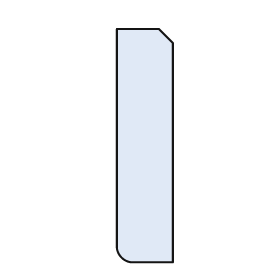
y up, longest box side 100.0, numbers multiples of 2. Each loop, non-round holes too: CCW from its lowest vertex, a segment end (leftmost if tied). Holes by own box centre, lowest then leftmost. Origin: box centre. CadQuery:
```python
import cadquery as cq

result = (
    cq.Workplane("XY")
    .moveTo(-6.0, -50.0)
    .lineTo(12.0, -50.0)
    .lineTo(12.0, 44.0)
    .lineTo(6.0, 50.0)
    .lineTo(-12.0, 50.0)
    .lineTo(-12.0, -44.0)
    .threePointArc((-10.0, -48.0), (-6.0, -50.0))
    .close()
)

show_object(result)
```